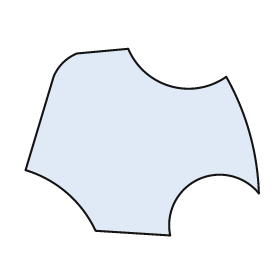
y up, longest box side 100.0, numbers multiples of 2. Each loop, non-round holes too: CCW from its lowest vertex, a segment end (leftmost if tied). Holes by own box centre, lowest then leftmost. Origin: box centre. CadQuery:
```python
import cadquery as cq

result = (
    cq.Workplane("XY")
    .moveTo(12.0, -40.0)
    .threePointArc((24.0, -16.0), (50.0, -22.0))
    .threePointArc((46.0, 4.0), (36.0, 28.0))
    .threePointArc((12.0, 24.0), (-6.0, 40.0))
    .lineTo(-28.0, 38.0)
    .threePointArc((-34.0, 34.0), (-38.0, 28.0))
    .lineTo(-50.0, -12.0)
    .threePointArc((-32.0, -22.0), (-20.0, -38.0))
    .close()
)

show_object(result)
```